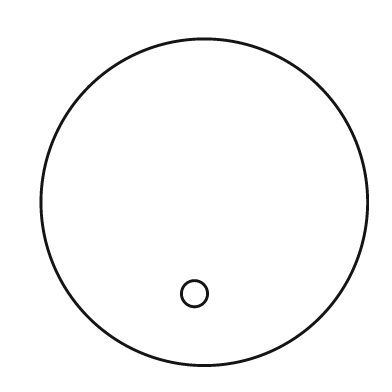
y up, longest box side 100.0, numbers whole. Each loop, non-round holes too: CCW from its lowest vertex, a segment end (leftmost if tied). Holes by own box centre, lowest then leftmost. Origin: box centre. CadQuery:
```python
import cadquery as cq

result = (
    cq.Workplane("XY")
    .moveTo(0.0, 0.0)
    .circle(50.0)
    .moveTo(-3.0, -28.0)
    .circle(4.0)
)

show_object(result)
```